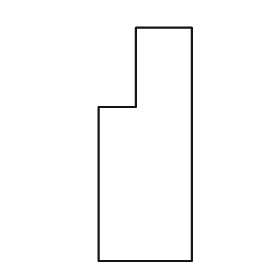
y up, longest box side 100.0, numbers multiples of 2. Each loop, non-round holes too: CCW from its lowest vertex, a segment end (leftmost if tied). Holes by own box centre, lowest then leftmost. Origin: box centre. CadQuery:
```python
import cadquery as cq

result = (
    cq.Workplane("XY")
    .moveTo(-20.0, -50.0)
    .lineTo(20.0, -50.0)
    .lineTo(20.0, 50.0)
    .lineTo(-4.0, 50.0)
    .lineTo(-4.0, 16.0)
    .lineTo(-20.0, 16.0)
    .close()
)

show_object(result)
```